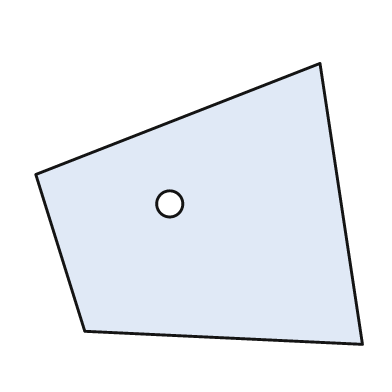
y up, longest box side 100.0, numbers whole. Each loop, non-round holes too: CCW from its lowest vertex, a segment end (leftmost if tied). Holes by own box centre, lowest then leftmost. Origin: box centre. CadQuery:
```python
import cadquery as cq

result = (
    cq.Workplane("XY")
    .moveTo(50.0, -43.0)
    .lineTo(37.0, 43.0)
    .lineTo(-50.0, 9.0)
    .lineTo(-35.0, -39.0)
    .close()
    .moveTo(-9.0, 0.0)
    .circle(4.0)
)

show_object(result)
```